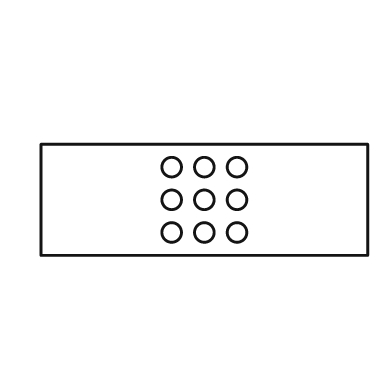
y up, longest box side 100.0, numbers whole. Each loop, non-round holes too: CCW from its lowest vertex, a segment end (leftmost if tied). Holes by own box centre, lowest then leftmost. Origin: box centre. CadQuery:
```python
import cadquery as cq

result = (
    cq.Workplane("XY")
    .moveTo(-50.0, -17.0)
    .lineTo(50.0, -17.0)
    .lineTo(50.0, 17.0)
    .lineTo(-50.0, 17.0)
    .close()
    .moveTo(-10.0, -10.0)
    .circle(3.0)
    .moveTo(0.0, -10.0)
    .circle(3.0)
    .moveTo(10.0, -10.0)
    .circle(3.0)
    .moveTo(-10.0, 0.0)
    .circle(3.0)
    .moveTo(0.0, 0.0)
    .circle(3.0)
    .moveTo(10.0, 0.0)
    .circle(3.0)
    .moveTo(-10.0, 10.0)
    .circle(3.0)
    .moveTo(0.0, 10.0)
    .circle(3.0)
    .moveTo(10.0, 10.0)
    .circle(3.0)
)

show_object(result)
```